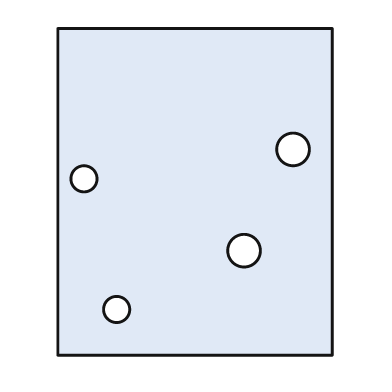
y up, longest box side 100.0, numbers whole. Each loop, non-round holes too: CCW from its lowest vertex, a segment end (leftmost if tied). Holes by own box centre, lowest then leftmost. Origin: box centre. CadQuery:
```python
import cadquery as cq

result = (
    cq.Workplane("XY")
    .moveTo(-42.0, -50.0)
    .lineTo(42.0, -50.0)
    .lineTo(42.0, 50.0)
    .lineTo(-42.0, 50.0)
    .close()
    .moveTo(-24.0, -36.0)
    .circle(4.0)
    .moveTo(15.0, -18.0)
    .circle(5.0)
    .moveTo(-34.0, 4.0)
    .circle(4.0)
    .moveTo(30.0, 13.0)
    .circle(5.0)
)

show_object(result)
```